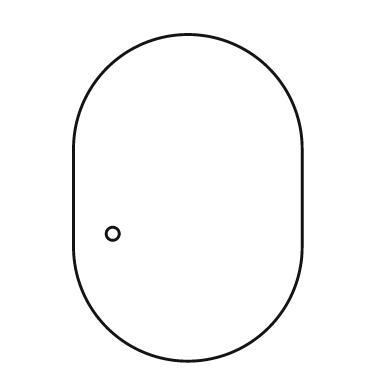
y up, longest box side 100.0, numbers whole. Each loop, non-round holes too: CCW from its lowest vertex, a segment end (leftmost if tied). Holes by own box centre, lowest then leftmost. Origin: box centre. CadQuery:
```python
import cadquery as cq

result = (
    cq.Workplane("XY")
    .moveTo(-35.0, -15.0)
    .threePointArc((0.0, -50.0), (35.0, -15.0))
    .lineTo(35.0, 15.0)
    .threePointArc((0.0, 50.0), (-35.0, 15.0))
    .close()
    .moveTo(-23.0, -11.0)
    .circle(2.0)
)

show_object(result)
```